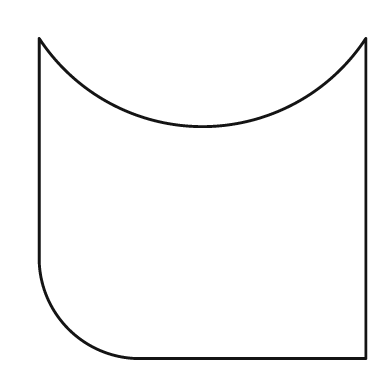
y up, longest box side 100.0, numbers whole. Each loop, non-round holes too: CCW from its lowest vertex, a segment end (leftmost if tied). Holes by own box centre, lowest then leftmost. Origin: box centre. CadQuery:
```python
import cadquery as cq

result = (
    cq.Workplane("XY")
    .moveTo(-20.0, -49.0)
    .lineTo(50.0, -49.0)
    .lineTo(50.0, 49.0)
    .threePointArc((0.0, 22.0), (-50.0, 49.0))
    .lineTo(-50.0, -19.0)
    .threePointArc((-41.0, -40.0), (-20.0, -49.0))
    .close()
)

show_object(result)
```